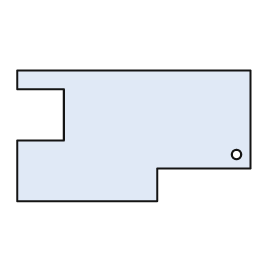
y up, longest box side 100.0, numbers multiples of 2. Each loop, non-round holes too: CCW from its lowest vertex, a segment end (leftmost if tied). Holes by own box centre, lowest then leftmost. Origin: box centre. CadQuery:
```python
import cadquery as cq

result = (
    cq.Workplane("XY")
    .moveTo(-50.0, -28.0)
    .lineTo(10.0, -28.0)
    .lineTo(10.0, -14.0)
    .lineTo(50.0, -14.0)
    .lineTo(50.0, 28.0)
    .lineTo(-50.0, 28.0)
    .lineTo(-50.0, 20.0)
    .lineTo(-30.0, 20.0)
    .lineTo(-30.0, -2.0)
    .lineTo(-50.0, -2.0)
    .close()
    .moveTo(44.0, -8.0)
    .circle(2.0)
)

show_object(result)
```